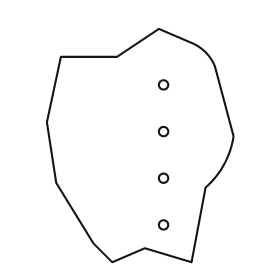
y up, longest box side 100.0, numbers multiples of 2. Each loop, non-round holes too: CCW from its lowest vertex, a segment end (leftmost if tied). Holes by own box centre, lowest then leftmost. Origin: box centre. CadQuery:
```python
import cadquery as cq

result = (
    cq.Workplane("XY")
    .moveTo(-12.0, -50.0)
    .lineTo(2.0, -44.0)
    .lineTo(22.0, -50.0)
    .lineTo(28.0, -18.0)
    .threePointArc((36.0, -8.0), (40.0, 4.0))
    .lineTo(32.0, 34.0)
    .threePointArc((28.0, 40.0), (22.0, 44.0))
    .lineTo(8.0, 50.0)
    .lineTo(-10.0, 38.0)
    .lineTo(-34.0, 38.0)
    .lineTo(-40.0, 10.0)
    .lineTo(-36.0, -16.0)
    .lineTo(-20.0, -42.0)
    .close()
    .moveTo(10.0, -34.0)
    .circle(2.0)
    .moveTo(10.0, -14.0)
    .circle(2.0)
    .moveTo(10.0, 6.0)
    .circle(2.0)
    .moveTo(10.0, 26.0)
    .circle(2.0)
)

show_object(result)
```